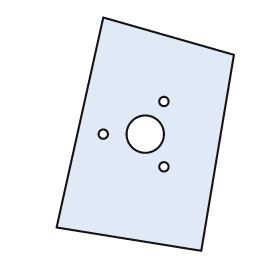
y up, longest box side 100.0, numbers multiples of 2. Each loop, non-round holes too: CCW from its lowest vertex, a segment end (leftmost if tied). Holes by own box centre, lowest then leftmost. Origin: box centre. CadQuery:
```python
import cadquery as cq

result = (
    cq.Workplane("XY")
    .moveTo(24.0, -50.0)
    .lineTo(38.0, 34.0)
    .lineTo(-18.0, 50.0)
    .lineTo(-38.0, -40.0)
    .close()
    .moveTo(8.0, -14.0)
    .circle(2.0)
    .moveTo(-18.0, 0.0)
    .circle(2.0)
    .moveTo(0.0, 0.0)
    .circle(8.0)
    .moveTo(8.0, 14.0)
    .circle(2.0)
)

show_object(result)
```